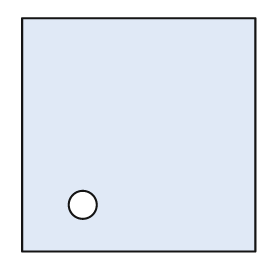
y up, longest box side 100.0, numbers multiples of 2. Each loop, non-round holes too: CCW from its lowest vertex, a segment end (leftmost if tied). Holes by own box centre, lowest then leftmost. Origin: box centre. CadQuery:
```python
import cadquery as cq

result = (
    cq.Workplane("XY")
    .moveTo(-50.0, -50.0)
    .lineTo(50.0, -50.0)
    .lineTo(50.0, 50.0)
    .lineTo(-50.0, 50.0)
    .close()
    .moveTo(-24.0, -30.0)
    .circle(6.0)
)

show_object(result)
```